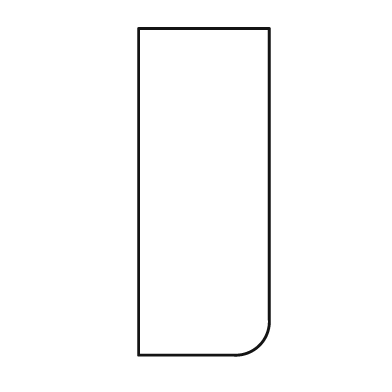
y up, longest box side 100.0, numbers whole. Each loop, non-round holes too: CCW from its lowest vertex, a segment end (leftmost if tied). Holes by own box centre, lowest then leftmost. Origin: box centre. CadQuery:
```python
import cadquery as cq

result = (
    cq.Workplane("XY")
    .moveTo(-20.0, -50.0)
    .lineTo(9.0, -50.0)
    .threePointArc((17.0, -47.0), (20.0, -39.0))
    .lineTo(20.0, 50.0)
    .lineTo(-20.0, 50.0)
    .close()
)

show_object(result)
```